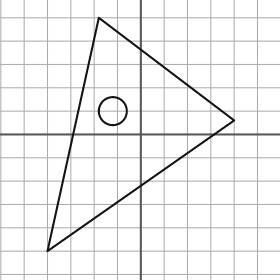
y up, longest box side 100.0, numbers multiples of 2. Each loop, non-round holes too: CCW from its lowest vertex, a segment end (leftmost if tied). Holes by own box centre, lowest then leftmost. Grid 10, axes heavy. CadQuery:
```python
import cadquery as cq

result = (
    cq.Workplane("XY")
    .moveTo(-40.0, -50.0)
    .lineTo(40.0, 6.0)
    .lineTo(-18.0, 50.0)
    .close()
    .moveTo(-12.0, 10.0)
    .circle(6.0)
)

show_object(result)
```